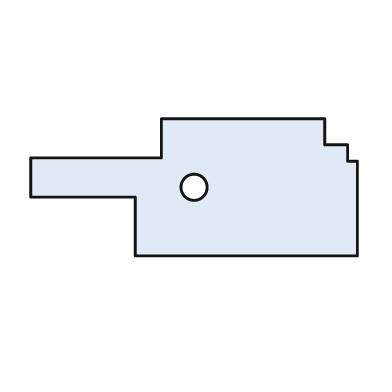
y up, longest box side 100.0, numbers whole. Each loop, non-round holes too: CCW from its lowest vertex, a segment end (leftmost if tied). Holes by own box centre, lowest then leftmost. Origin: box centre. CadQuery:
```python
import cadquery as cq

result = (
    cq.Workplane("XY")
    .moveTo(-18.0, -21.0)
    .lineTo(50.0, -21.0)
    .lineTo(50.0, 8.0)
    .lineTo(47.0, 8.0)
    .lineTo(47.0, 13.0)
    .lineTo(40.0, 13.0)
    .lineTo(40.0, 21.0)
    .lineTo(-10.0, 21.0)
    .lineTo(-10.0, 9.0)
    .lineTo(-50.0, 9.0)
    .lineTo(-50.0, -3.0)
    .lineTo(-18.0, -3.0)
    .close()
    .moveTo(0.0, 0.0)
    .circle(4.0)
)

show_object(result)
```